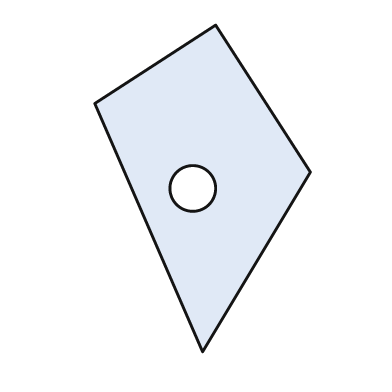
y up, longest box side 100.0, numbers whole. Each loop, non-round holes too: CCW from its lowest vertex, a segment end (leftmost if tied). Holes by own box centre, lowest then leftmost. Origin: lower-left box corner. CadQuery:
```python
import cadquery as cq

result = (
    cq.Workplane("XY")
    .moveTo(33.0, 0.0)
    .lineTo(66.0, 55.0)
    .lineTo(37.0, 100.0)
    .lineTo(0.0, 76.0)
    .close()
    .moveTo(30.0, 50.0)
    .circle(7.0)
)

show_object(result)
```